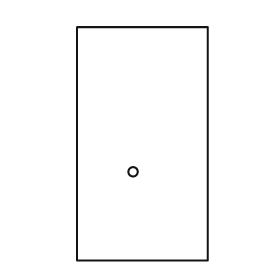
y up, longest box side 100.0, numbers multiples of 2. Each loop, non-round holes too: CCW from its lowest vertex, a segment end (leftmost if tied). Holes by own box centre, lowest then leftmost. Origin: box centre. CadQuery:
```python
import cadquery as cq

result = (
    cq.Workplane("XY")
    .moveTo(-28.0, -50.0)
    .lineTo(28.0, -50.0)
    .lineTo(28.0, 50.0)
    .lineTo(-28.0, 50.0)
    .close()
    .moveTo(-4.0, -12.0)
    .circle(2.0)
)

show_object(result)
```